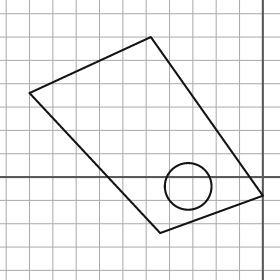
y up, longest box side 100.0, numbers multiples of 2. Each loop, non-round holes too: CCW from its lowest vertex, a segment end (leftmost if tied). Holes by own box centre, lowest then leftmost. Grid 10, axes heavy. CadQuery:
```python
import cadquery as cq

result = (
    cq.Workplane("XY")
    .moveTo(-44.0, -24.0)
    .lineTo(0.0, -8.0)
    .lineTo(-48.0, 60.0)
    .lineTo(-100.0, 36.0)
    .close()
    .moveTo(-32.0, -4.0)
    .circle(10.0)
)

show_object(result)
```